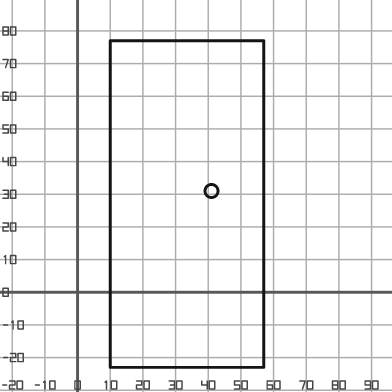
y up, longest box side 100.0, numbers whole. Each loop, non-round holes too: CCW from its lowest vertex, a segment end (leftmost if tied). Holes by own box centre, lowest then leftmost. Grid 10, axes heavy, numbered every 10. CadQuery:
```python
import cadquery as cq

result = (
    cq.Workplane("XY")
    .moveTo(10.0, -23.0)
    .lineTo(57.0, -23.0)
    .lineTo(57.0, 77.0)
    .lineTo(10.0, 77.0)
    .close()
    .moveTo(41.0, 31.0)
    .circle(2.0)
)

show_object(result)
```